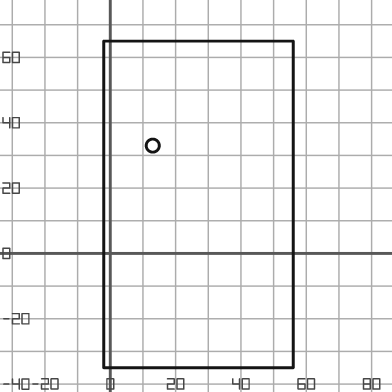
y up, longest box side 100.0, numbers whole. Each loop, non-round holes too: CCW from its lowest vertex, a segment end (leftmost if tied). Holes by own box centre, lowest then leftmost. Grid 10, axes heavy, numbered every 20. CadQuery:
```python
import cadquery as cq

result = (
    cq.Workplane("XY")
    .moveTo(-2.0, -35.0)
    .lineTo(56.0, -35.0)
    .lineTo(56.0, 65.0)
    .lineTo(-2.0, 65.0)
    .close()
    .moveTo(13.0, 33.0)
    .circle(2.0)
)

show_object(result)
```